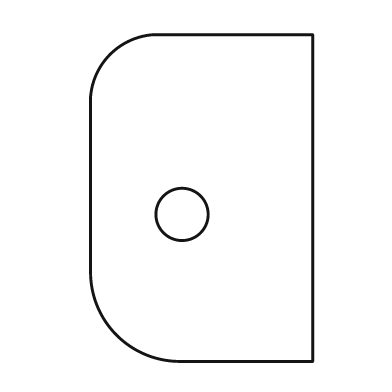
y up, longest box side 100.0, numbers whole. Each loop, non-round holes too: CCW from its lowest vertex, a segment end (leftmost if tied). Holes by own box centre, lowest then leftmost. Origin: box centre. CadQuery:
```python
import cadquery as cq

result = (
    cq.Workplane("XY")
    .moveTo(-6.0, -50.0)
    .lineTo(34.0, -50.0)
    .lineTo(34.0, 50.0)
    .lineTo(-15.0, 50.0)
    .threePointArc((-28.0, 44.0), (-34.0, 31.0))
    .lineTo(-34.0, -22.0)
    .threePointArc((-26.0, -42.0), (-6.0, -50.0))
    .close()
    .moveTo(-6.0, -5.0)
    .circle(8.0)
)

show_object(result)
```